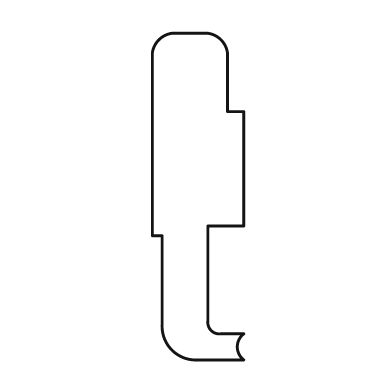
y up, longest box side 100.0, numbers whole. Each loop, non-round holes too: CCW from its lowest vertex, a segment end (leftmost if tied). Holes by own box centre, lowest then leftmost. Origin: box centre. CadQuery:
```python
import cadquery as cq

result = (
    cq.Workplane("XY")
    .moveTo(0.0, -50.0)
    .lineTo(14.0, -50.0)
    .threePointArc((12.0, -46.0), (14.0, -42.0))
    .lineTo(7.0, -42.0)
    .threePointArc((4.0, -41.0), (3.0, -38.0))
    .lineTo(3.0, -9.0)
    .lineTo(14.0, -9.0)
    .lineTo(14.0, 26.0)
    .lineTo(9.0, 26.0)
    .lineTo(9.0, 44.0)
    .threePointArc((7.0, 48.0), (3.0, 50.0))
    .lineTo(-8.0, 50.0)
    .threePointArc((-12.0, 48.0), (-14.0, 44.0))
    .lineTo(-14.0, -12.0)
    .lineTo(-11.0, -12.0)
    .lineTo(-11.0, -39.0)
    .threePointArc((-8.0, -47.0), (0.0, -50.0))
    .close()
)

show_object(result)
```